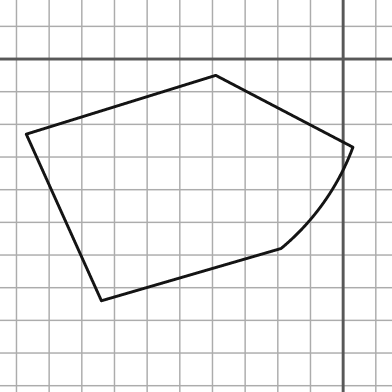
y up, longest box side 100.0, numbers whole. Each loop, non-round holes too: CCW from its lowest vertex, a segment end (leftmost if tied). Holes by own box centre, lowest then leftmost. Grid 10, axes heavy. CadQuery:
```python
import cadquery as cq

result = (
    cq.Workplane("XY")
    .moveTo(-74.0, -74.0)
    .lineTo(-19.0, -58.0)
    .threePointArc((-6.0, -44.0), (3.0, -27.0))
    .lineTo(-39.0, -5.0)
    .lineTo(-97.0, -23.0)
    .close()
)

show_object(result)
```